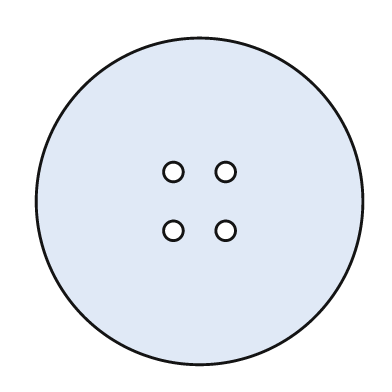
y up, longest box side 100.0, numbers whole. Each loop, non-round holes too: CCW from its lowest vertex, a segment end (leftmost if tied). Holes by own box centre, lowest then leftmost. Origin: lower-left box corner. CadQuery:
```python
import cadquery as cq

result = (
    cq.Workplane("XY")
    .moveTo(50.0, 50.0)
    .circle(50.0)
    .moveTo(42.0, 41.0)
    .circle(3.0)
    .moveTo(58.0, 41.0)
    .circle(3.0)
    .moveTo(42.0, 59.0)
    .circle(3.0)
    .moveTo(58.0, 59.0)
    .circle(3.0)
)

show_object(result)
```